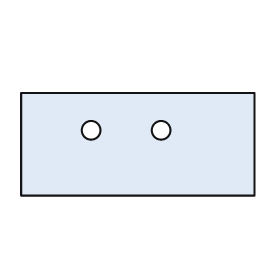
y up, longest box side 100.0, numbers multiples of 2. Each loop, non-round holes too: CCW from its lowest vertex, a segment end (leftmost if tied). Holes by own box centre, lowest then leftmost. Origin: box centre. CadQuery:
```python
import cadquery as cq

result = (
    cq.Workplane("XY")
    .moveTo(-50.0, -22.0)
    .lineTo(50.0, -22.0)
    .lineTo(50.0, 22.0)
    .lineTo(-50.0, 22.0)
    .close()
    .moveTo(-20.0, 6.0)
    .circle(4.0)
    .moveTo(10.0, 6.0)
    .circle(4.0)
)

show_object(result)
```